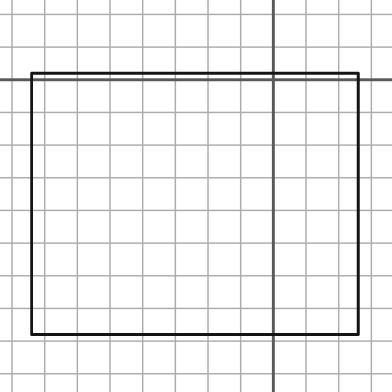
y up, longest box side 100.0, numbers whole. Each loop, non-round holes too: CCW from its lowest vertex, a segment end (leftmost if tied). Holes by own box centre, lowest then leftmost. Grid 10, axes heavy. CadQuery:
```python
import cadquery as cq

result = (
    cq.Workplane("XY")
    .moveTo(-74.0, -78.0)
    .lineTo(26.0, -78.0)
    .lineTo(26.0, 2.0)
    .lineTo(-74.0, 2.0)
    .close()
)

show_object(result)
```